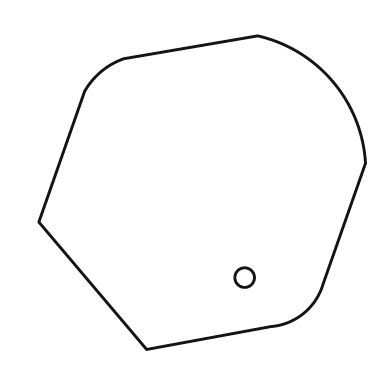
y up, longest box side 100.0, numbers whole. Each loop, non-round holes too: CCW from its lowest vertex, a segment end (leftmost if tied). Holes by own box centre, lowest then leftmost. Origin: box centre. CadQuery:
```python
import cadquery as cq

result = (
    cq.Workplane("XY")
    .moveTo(-17.0, -48.0)
    .lineTo(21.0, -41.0)
    .threePointArc((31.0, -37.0), (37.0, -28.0))
    .lineTo(50.0, 9.0)
    .threePointArc((40.0, 34.0), (17.0, 48.0))
    .lineTo(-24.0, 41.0)
    .threePointArc((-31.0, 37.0), (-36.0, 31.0))
    .lineTo(-50.0, -9.0)
    .close()
    .moveTo(13.0, -26.0)
    .circle(3.0)
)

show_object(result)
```